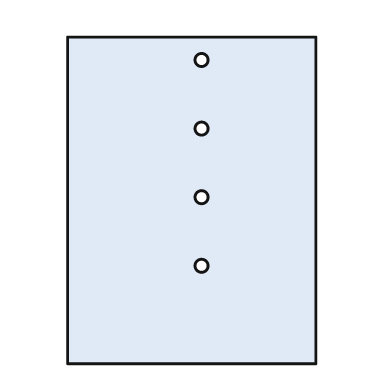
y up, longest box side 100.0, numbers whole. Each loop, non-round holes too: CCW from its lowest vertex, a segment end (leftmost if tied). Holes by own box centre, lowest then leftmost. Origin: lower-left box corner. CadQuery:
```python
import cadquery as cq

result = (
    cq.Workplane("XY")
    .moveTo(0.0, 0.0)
    .lineTo(76.0, 0.0)
    .lineTo(76.0, 100.0)
    .lineTo(0.0, 100.0)
    .close()
    .moveTo(41.0, 30.0)
    .circle(2.0)
    .moveTo(41.0, 51.0)
    .circle(2.0)
    .moveTo(41.0, 72.0)
    .circle(2.0)
    .moveTo(41.0, 93.0)
    .circle(2.0)
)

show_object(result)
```